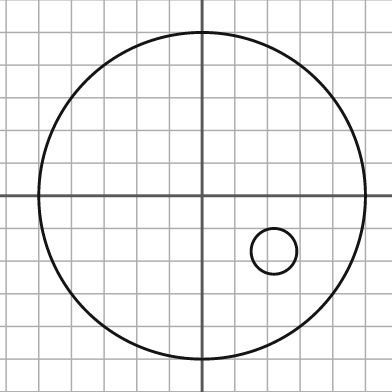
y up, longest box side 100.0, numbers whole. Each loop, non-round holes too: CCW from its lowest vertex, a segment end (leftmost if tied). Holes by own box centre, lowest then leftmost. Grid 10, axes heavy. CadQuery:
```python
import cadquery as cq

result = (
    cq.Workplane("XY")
    .moveTo(0.0, 0.0)
    .circle(50.0)
    .moveTo(22.0, -17.0)
    .circle(7.0)
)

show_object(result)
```